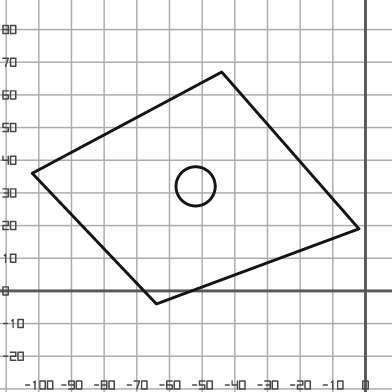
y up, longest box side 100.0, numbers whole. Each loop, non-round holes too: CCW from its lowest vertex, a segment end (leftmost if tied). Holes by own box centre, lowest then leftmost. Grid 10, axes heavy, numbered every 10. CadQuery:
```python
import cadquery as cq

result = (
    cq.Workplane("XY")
    .moveTo(-64.0, -4.0)
    .lineTo(-2.0, 19.0)
    .lineTo(-44.0, 67.0)
    .lineTo(-102.0, 36.0)
    .close()
    .moveTo(-52.0, 32.0)
    .circle(6.0)
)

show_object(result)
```